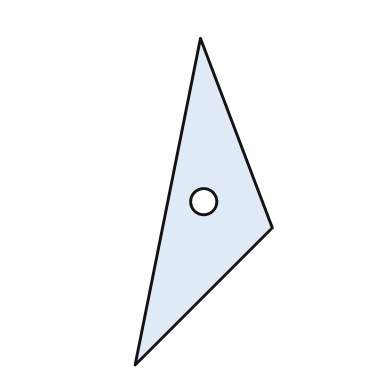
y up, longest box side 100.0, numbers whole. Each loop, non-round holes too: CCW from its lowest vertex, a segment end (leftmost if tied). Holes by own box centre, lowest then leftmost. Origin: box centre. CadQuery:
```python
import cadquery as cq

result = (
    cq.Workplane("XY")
    .moveTo(-21.0, -50.0)
    .lineTo(21.0, -8.0)
    .lineTo(-1.0, 50.0)
    .close()
    .moveTo(0.0, 0.0)
    .circle(4.0)
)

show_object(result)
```